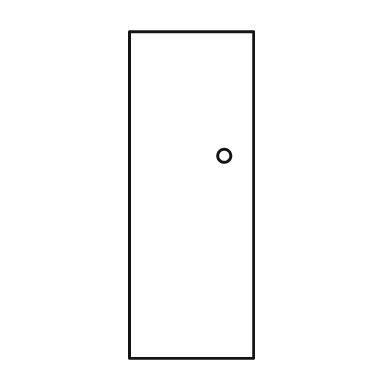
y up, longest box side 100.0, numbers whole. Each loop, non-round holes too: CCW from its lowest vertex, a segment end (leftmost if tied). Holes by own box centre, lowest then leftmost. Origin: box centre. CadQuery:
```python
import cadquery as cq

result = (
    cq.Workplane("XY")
    .moveTo(-19.0, -50.0)
    .lineTo(19.0, -50.0)
    .lineTo(19.0, 50.0)
    .lineTo(-19.0, 50.0)
    .close()
    .moveTo(10.0, 12.0)
    .circle(2.0)
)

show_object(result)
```